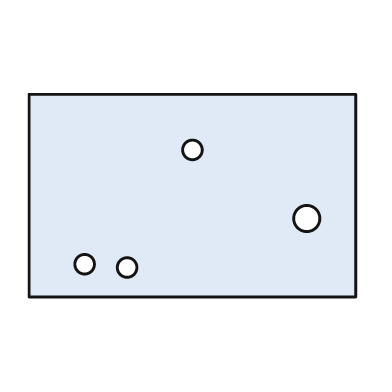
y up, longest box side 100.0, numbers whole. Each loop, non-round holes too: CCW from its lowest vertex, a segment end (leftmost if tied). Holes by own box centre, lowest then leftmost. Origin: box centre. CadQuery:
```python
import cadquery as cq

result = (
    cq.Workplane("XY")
    .moveTo(-50.0, -31.0)
    .lineTo(50.0, -31.0)
    .lineTo(50.0, 31.0)
    .lineTo(-50.0, 31.0)
    .close()
    .moveTo(-20.0, -22.0)
    .circle(3.0)
    .moveTo(-33.0, -21.0)
    .circle(3.0)
    .moveTo(35.0, -7.0)
    .circle(4.0)
    .moveTo(0.0, 14.0)
    .circle(3.0)
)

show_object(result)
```